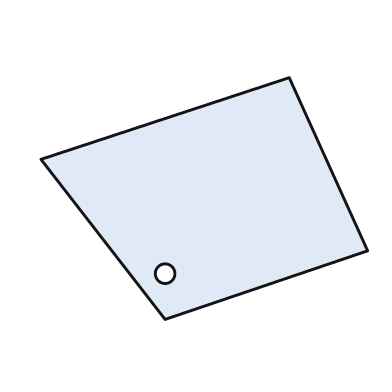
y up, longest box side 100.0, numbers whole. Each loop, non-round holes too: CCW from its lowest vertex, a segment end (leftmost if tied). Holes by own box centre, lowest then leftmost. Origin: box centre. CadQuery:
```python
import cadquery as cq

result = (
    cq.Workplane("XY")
    .moveTo(-12.0, -37.0)
    .lineTo(50.0, -16.0)
    .lineTo(26.0, 37.0)
    .lineTo(-50.0, 12.0)
    .close()
    .moveTo(-12.0, -23.0)
    .circle(3.0)
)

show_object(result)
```